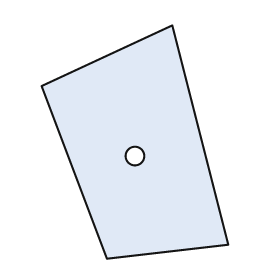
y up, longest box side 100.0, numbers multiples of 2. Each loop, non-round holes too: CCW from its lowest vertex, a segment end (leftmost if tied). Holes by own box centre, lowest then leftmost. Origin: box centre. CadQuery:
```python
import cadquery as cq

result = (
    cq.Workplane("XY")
    .moveTo(-12.0, -50.0)
    .lineTo(40.0, -44.0)
    .lineTo(16.0, 50.0)
    .lineTo(-40.0, 24.0)
    .close()
    .moveTo(0.0, -6.0)
    .circle(4.0)
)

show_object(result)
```